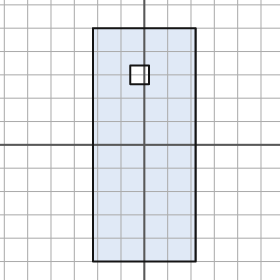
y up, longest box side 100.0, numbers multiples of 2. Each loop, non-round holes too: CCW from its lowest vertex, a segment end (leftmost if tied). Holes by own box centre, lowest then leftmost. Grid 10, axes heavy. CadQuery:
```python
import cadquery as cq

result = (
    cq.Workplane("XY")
    .moveTo(-22.0, -50.0)
    .lineTo(22.0, -50.0)
    .lineTo(22.0, 50.0)
    .lineTo(-22.0, 50.0)
    .close()
    .moveTo(-6.0, 26.0)
    .lineTo(2.0, 26.0)
    .lineTo(2.0, 34.0)
    .lineTo(-6.0, 34.0)
    .close()
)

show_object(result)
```